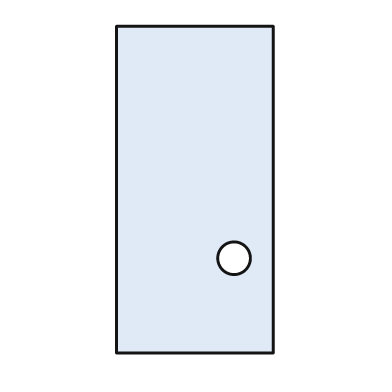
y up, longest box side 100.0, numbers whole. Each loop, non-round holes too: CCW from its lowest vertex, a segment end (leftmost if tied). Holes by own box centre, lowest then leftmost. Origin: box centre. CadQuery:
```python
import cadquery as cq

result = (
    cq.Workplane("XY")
    .moveTo(-24.0, -50.0)
    .lineTo(24.0, -50.0)
    .lineTo(24.0, 50.0)
    .lineTo(-24.0, 50.0)
    .close()
    .moveTo(12.0, -21.0)
    .circle(5.0)
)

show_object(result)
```